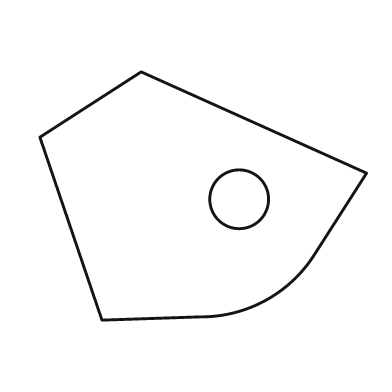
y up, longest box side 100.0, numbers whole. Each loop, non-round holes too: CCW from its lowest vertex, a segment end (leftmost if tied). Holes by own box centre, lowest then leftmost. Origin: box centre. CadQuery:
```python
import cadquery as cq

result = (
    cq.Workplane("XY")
    .moveTo(-31.0, -38.0)
    .lineTo(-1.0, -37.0)
    .threePointArc((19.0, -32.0), (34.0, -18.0))
    .lineTo(50.0, 7.0)
    .lineTo(-19.0, 38.0)
    .lineTo(-50.0, 18.0)
    .close()
    .moveTo(11.0, -1.0)
    .circle(9.0)
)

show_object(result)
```